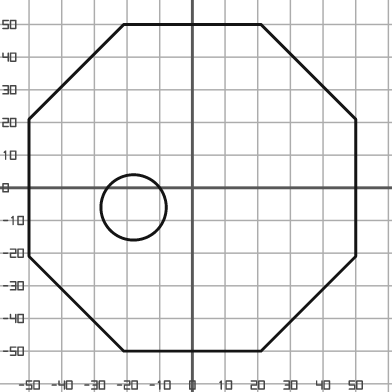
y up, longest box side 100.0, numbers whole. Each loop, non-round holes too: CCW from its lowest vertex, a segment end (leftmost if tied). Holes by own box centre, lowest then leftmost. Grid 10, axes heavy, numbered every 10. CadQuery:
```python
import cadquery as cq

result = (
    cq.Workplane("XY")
    .moveTo(-21.0, -50.0)
    .lineTo(21.0, -50.0)
    .lineTo(50.0, -21.0)
    .lineTo(50.0, 21.0)
    .lineTo(21.0, 50.0)
    .lineTo(-21.0, 50.0)
    .lineTo(-50.0, 21.0)
    .lineTo(-50.0, -21.0)
    .close()
    .moveTo(-18.0, -6.0)
    .circle(10.0)
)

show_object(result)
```